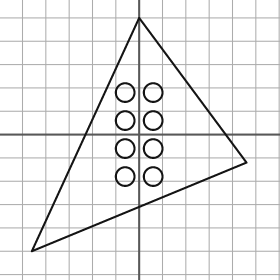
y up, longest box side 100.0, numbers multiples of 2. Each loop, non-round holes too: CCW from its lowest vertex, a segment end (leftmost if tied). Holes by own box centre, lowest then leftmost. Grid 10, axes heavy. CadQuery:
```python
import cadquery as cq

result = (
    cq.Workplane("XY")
    .moveTo(-46.0, -50.0)
    .lineTo(46.0, -12.0)
    .lineTo(0.0, 50.0)
    .close()
    .moveTo(-6.0, -18.0)
    .circle(4.0)
    .moveTo(6.0, -18.0)
    .circle(4.0)
    .moveTo(-6.0, -6.0)
    .circle(4.0)
    .moveTo(6.0, -6.0)
    .circle(4.0)
    .moveTo(-6.0, 6.0)
    .circle(4.0)
    .moveTo(6.0, 6.0)
    .circle(4.0)
    .moveTo(-6.0, 18.0)
    .circle(4.0)
    .moveTo(6.0, 18.0)
    .circle(4.0)
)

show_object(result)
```